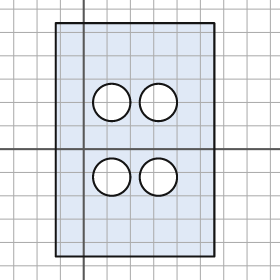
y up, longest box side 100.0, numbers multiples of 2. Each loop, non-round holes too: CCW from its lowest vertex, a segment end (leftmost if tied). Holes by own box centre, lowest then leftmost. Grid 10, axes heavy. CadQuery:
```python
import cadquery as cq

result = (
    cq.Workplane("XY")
    .moveTo(-12.0, -46.0)
    .lineTo(56.0, -46.0)
    .lineTo(56.0, 54.0)
    .lineTo(-12.0, 54.0)
    .close()
    .moveTo(12.0, -12.0)
    .circle(8.0)
    .moveTo(32.0, -12.0)
    .circle(8.0)
    .moveTo(12.0, 20.0)
    .circle(8.0)
    .moveTo(32.0, 20.0)
    .circle(8.0)
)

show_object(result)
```